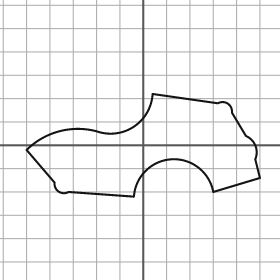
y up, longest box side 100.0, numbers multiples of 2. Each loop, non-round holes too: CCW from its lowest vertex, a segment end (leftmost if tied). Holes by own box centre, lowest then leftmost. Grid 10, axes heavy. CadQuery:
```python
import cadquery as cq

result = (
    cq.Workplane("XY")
    .moveTo(-4.0, -22.0)
    .threePointArc((12.0, -6.0), (30.0, -20.0))
    .lineTo(50.0, -14.0)
    .lineTo(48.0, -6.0)
    .threePointArc((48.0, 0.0), (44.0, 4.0))
    .lineTo(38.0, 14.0)
    .threePointArc((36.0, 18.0), (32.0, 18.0))
    .lineTo(4.0, 22.0)
    .threePointArc((-4.0, 8.0), (-20.0, 6.0))
    .threePointArc((-36.0, 6.0), (-50.0, -2.0))
    .lineTo(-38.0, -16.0)
    .threePointArc((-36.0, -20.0), (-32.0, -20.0))
    .close()
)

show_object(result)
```